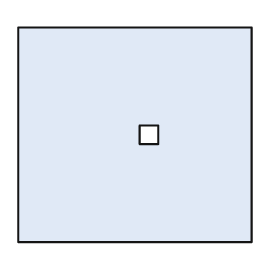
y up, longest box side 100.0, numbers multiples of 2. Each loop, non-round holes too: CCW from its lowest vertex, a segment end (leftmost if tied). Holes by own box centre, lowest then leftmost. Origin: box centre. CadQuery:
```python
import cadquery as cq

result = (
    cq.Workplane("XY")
    .moveTo(-50.0, -46.0)
    .lineTo(50.0, -46.0)
    .lineTo(50.0, 46.0)
    .lineTo(-50.0, 46.0)
    .close()
    .moveTo(2.0, -4.0)
    .lineTo(10.0, -4.0)
    .lineTo(10.0, 4.0)
    .lineTo(2.0, 4.0)
    .close()
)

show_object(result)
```